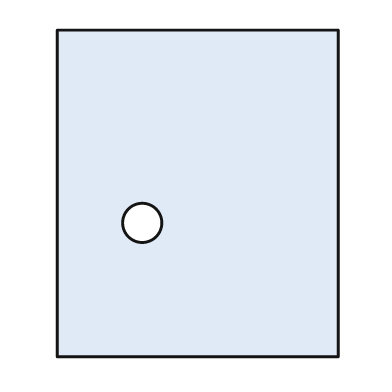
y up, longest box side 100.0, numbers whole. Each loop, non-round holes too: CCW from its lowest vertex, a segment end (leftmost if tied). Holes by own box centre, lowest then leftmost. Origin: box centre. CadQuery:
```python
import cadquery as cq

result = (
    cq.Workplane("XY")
    .moveTo(-43.0, -50.0)
    .lineTo(43.0, -50.0)
    .lineTo(43.0, 50.0)
    .lineTo(-43.0, 50.0)
    .close()
    .moveTo(-17.0, -9.0)
    .circle(6.0)
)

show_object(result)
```